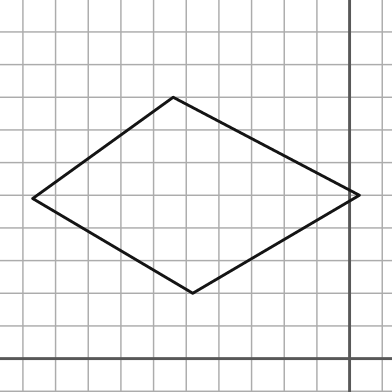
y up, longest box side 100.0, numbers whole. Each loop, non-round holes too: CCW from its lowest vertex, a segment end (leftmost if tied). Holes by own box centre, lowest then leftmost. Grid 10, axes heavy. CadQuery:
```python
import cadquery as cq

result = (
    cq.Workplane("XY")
    .moveTo(-48.0, 20.0)
    .lineTo(3.0, 50.0)
    .lineTo(-54.0, 80.0)
    .lineTo(-97.0, 49.0)
    .close()
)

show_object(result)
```